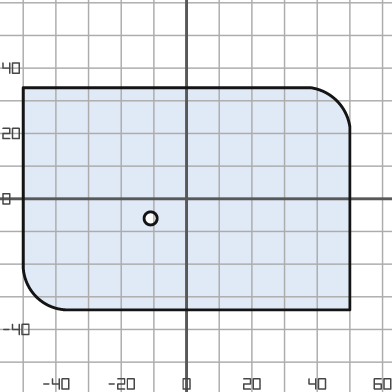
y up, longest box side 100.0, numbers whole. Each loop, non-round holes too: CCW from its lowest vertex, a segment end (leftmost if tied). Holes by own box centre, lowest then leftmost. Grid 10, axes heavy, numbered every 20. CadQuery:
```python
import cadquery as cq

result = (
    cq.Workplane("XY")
    .moveTo(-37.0, -34.0)
    .lineTo(50.0, -34.0)
    .lineTo(50.0, 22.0)
    .threePointArc((46.0, 30.0), (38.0, 34.0))
    .lineTo(-50.0, 34.0)
    .lineTo(-50.0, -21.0)
    .threePointArc((-46.0, -30.0), (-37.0, -34.0))
    .close()
    .moveTo(-11.0, -6.0)
    .circle(2.0)
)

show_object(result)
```